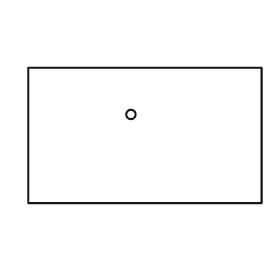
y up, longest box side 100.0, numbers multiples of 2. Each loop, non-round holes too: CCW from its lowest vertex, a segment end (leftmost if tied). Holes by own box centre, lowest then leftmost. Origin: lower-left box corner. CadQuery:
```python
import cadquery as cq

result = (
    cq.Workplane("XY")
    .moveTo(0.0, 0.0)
    .lineTo(100.0, 0.0)
    .lineTo(100.0, 58.0)
    .lineTo(0.0, 58.0)
    .close()
    .moveTo(44.0, 38.0)
    .circle(2.0)
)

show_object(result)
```